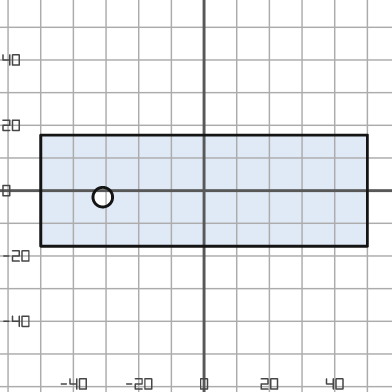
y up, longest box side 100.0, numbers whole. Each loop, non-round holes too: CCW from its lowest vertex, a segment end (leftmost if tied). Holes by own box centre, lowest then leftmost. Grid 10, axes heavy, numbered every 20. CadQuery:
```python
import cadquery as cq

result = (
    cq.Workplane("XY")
    .moveTo(-50.0, -17.0)
    .lineTo(50.0, -17.0)
    .lineTo(50.0, 17.0)
    .lineTo(-50.0, 17.0)
    .close()
    .moveTo(-31.0, -2.0)
    .circle(3.0)
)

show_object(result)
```